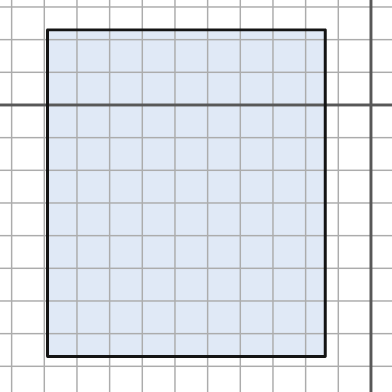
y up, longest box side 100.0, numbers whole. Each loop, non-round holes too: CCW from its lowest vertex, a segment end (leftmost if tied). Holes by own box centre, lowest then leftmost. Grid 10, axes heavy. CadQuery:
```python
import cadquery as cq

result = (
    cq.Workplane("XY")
    .moveTo(-99.0, -77.0)
    .lineTo(-14.0, -77.0)
    .lineTo(-14.0, 23.0)
    .lineTo(-99.0, 23.0)
    .close()
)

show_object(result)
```